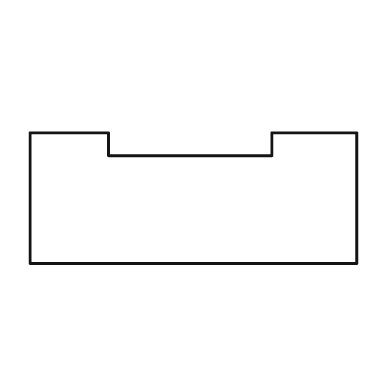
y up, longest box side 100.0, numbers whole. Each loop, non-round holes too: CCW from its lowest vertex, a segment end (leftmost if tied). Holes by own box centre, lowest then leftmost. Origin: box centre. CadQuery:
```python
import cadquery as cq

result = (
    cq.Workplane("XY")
    .moveTo(-50.0, -20.0)
    .lineTo(50.0, -20.0)
    .lineTo(50.0, 20.0)
    .lineTo(24.0, 20.0)
    .lineTo(24.0, 13.0)
    .lineTo(-26.0, 13.0)
    .lineTo(-26.0, 20.0)
    .lineTo(-50.0, 20.0)
    .close()
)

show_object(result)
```